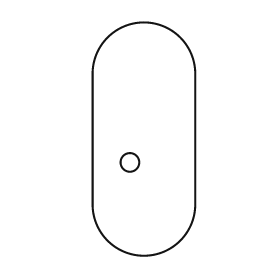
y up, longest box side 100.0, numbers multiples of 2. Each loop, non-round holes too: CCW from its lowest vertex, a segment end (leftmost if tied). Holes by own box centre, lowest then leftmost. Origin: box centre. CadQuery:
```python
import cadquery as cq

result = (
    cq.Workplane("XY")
    .moveTo(-22.0, -28.0)
    .threePointArc((0.0, -50.0), (22.0, -28.0))
    .lineTo(22.0, 28.0)
    .threePointArc((0.0, 50.0), (-22.0, 28.0))
    .close()
    .moveTo(-6.0, -10.0)
    .circle(4.0)
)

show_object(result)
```